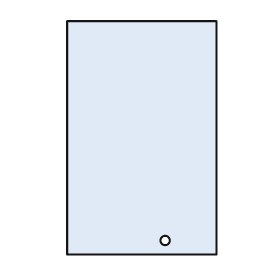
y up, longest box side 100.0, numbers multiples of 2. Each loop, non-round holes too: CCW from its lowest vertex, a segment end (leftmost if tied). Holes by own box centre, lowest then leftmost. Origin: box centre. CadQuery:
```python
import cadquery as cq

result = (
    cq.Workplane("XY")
    .moveTo(-32.0, -50.0)
    .lineTo(32.0, -50.0)
    .lineTo(32.0, 50.0)
    .lineTo(-32.0, 50.0)
    .close()
    .moveTo(10.0, -44.0)
    .circle(2.0)
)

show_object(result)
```